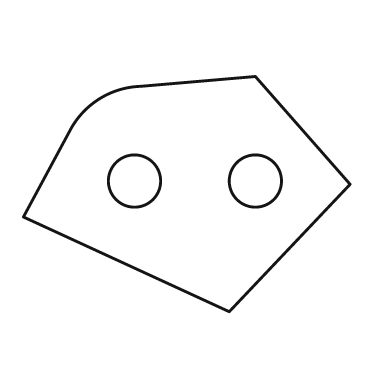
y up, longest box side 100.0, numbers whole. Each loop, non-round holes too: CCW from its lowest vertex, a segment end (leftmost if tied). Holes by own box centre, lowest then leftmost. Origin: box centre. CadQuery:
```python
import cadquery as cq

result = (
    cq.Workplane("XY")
    .moveTo(13.0, -36.0)
    .lineTo(50.0, 3.0)
    .lineTo(21.0, 36.0)
    .lineTo(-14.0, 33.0)
    .threePointArc((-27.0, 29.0), (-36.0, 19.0))
    .lineTo(-50.0, -7.0)
    .close()
    .moveTo(-16.0, 4.0)
    .circle(8.0)
    .moveTo(21.0, 4.0)
    .circle(8.0)
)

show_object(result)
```